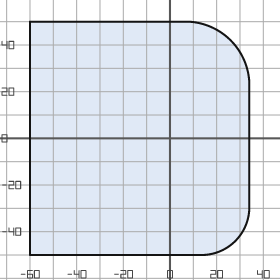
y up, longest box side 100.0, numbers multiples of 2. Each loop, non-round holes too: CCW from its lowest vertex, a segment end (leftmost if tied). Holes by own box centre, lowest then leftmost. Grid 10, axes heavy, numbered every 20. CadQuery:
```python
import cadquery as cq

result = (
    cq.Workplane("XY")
    .moveTo(-60.0, -50.0)
    .lineTo(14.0, -50.0)
    .threePointArc((28.0, -44.0), (34.0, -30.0))
    .lineTo(34.0, 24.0)
    .threePointArc((26.0, 42.0), (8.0, 50.0))
    .lineTo(-60.0, 50.0)
    .close()
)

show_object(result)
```